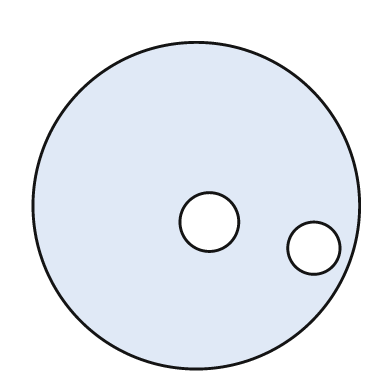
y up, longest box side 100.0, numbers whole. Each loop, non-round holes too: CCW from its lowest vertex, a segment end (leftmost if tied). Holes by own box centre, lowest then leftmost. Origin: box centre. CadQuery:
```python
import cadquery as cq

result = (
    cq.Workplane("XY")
    .moveTo(0.0, 0.0)
    .circle(50.0)
    .moveTo(36.0, -13.0)
    .circle(8.0)
    .moveTo(4.0, -5.0)
    .circle(9.0)
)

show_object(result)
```